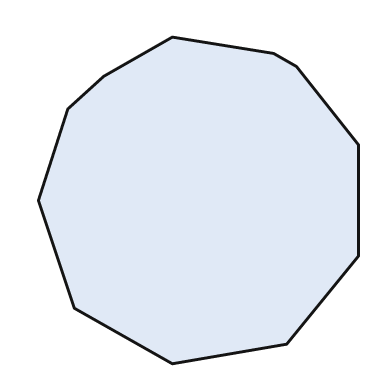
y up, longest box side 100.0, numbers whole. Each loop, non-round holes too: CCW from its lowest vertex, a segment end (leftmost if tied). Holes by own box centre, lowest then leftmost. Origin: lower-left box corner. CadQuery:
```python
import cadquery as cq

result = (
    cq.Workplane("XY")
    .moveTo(41.0, 0.0)
    .lineTo(76.0, 6.0)
    .lineTo(98.0, 33.0)
    .lineTo(98.0, 67.0)
    .lineTo(79.0, 91.0)
    .lineTo(72.0, 95.0)
    .lineTo(41.0, 100.0)
    .lineTo(20.0, 88.0)
    .lineTo(9.0, 78.0)
    .lineTo(0.0, 50.0)
    .lineTo(11.0, 17.0)
    .close()
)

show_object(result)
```